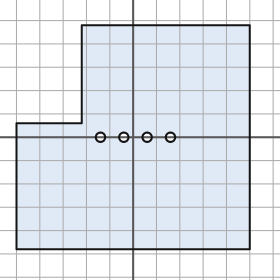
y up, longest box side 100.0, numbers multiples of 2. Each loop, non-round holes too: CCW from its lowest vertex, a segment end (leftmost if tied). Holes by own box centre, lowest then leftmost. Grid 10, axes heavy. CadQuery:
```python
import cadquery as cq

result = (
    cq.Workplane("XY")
    .moveTo(-50.0, -48.0)
    .lineTo(50.0, -48.0)
    .lineTo(50.0, 48.0)
    .lineTo(-22.0, 48.0)
    .lineTo(-22.0, 6.0)
    .lineTo(-50.0, 6.0)
    .close()
    .moveTo(-14.0, 0.0)
    .circle(2.0)
    .moveTo(-4.0, 0.0)
    .circle(2.0)
    .moveTo(6.0, 0.0)
    .circle(2.0)
    .moveTo(16.0, 0.0)
    .circle(2.0)
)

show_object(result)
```